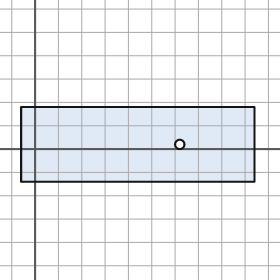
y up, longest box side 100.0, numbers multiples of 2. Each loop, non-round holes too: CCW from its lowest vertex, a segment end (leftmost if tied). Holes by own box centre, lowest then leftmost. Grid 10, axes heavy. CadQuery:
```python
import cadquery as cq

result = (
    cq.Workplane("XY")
    .moveTo(-6.0, -14.0)
    .lineTo(94.0, -14.0)
    .lineTo(94.0, 18.0)
    .lineTo(-6.0, 18.0)
    .close()
    .moveTo(62.0, 2.0)
    .circle(2.0)
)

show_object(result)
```